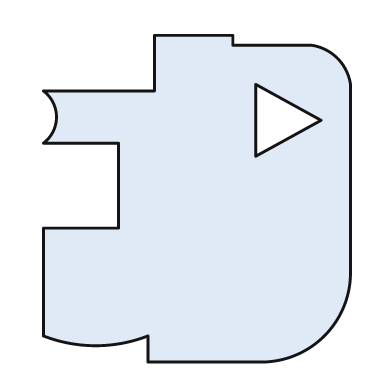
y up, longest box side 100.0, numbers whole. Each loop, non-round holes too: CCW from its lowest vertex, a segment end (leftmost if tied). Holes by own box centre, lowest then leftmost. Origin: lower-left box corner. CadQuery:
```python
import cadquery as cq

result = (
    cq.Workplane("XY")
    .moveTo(32.0, 0.0)
    .lineTo(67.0, 0.0)
    .threePointArc((86.0, 8.0), (94.0, 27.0))
    .lineTo(94.0, 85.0)
    .threePointArc((90.0, 93.0), (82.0, 97.0))
    .lineTo(58.0, 97.0)
    .lineTo(58.0, 100.0)
    .lineTo(34.0, 100.0)
    .lineTo(34.0, 83.0)
    .lineTo(0.0, 83.0)
    .threePointArc((4.0, 75.0), (0.0, 67.0))
    .lineTo(23.0, 67.0)
    .lineTo(23.0, 41.0)
    .lineTo(0.0, 41.0)
    .lineTo(0.0, 8.0)
    .threePointArc((16.0, 5.0), (32.0, 8.0))
    .close()
    .moveTo(65.0, 63.0)
    .lineTo(85.0, 74.0)
    .lineTo(65.0, 85.0)
    .close()
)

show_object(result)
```